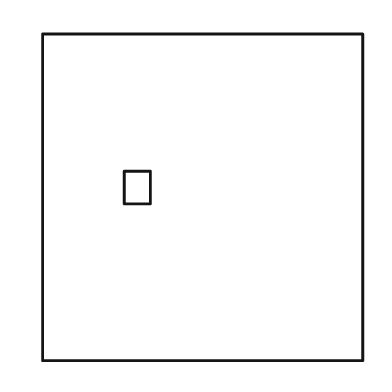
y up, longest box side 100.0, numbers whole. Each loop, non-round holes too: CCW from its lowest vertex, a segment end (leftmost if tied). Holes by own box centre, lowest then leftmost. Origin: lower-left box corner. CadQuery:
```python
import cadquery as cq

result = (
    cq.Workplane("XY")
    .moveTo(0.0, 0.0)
    .lineTo(98.0, 0.0)
    .lineTo(98.0, 100.0)
    .lineTo(0.0, 100.0)
    .close()
    .moveTo(25.0, 48.0)
    .lineTo(33.0, 48.0)
    .lineTo(33.0, 58.0)
    .lineTo(25.0, 58.0)
    .close()
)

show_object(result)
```